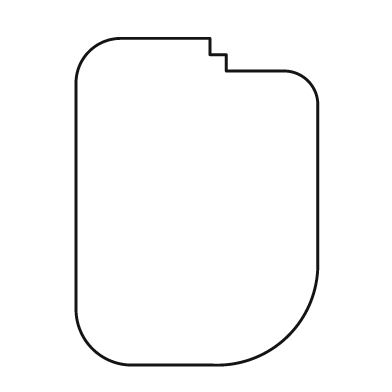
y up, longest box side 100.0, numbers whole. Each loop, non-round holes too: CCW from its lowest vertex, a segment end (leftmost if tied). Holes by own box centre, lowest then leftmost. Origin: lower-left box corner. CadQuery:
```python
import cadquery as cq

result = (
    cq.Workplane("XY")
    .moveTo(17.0, 0.0)
    .lineTo(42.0, 0.0)
    .threePointArc((65.0, 9.0), (74.0, 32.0))
    .lineTo(74.0, 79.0)
    .threePointArc((71.0, 87.0), (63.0, 90.0))
    .lineTo(46.0, 90.0)
    .lineTo(46.0, 95.0)
    .lineTo(41.0, 95.0)
    .lineTo(41.0, 100.0)
    .lineTo(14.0, 100.0)
    .threePointArc((4.0, 96.0), (0.0, 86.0))
    .lineTo(0.0, 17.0)
    .threePointArc((5.0, 5.0), (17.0, 0.0))
    .close()
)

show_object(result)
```